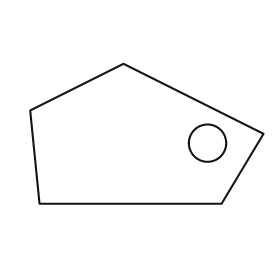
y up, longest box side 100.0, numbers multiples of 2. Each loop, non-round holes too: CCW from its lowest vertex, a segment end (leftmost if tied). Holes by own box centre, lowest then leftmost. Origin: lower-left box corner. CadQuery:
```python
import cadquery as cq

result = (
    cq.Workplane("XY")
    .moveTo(4.0, 0.0)
    .lineTo(82.0, 0.0)
    .lineTo(100.0, 30.0)
    .lineTo(40.0, 60.0)
    .lineTo(0.0, 40.0)
    .close()
    .moveTo(76.0, 26.0)
    .circle(8.0)
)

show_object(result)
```